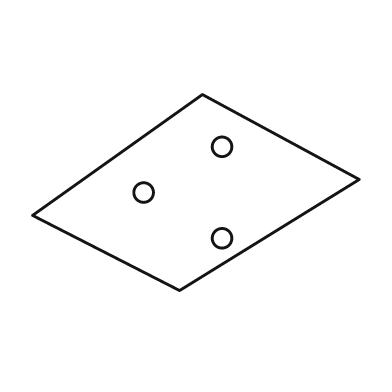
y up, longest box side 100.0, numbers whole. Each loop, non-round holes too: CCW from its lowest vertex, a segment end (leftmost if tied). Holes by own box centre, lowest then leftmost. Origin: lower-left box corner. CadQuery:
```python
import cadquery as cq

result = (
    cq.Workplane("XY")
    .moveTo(45.0, 0.0)
    .lineTo(100.0, 34.0)
    .lineTo(52.0, 60.0)
    .lineTo(0.0, 23.0)
    .close()
    .moveTo(58.0, 16.0)
    .circle(3.0)
    .moveTo(34.0, 30.0)
    .circle(3.0)
    .moveTo(58.0, 44.0)
    .circle(3.0)
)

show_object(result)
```